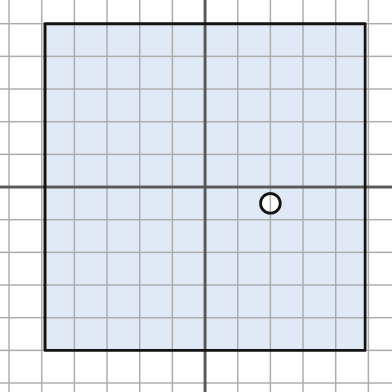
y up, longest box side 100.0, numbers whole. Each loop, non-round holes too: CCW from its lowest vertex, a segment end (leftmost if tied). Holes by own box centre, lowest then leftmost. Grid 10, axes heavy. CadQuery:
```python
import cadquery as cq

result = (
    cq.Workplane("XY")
    .moveTo(-49.0, -50.0)
    .lineTo(49.0, -50.0)
    .lineTo(49.0, 50.0)
    .lineTo(-49.0, 50.0)
    .close()
    .moveTo(20.0, -5.0)
    .circle(3.0)
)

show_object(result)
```